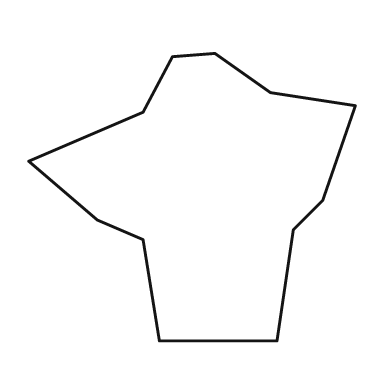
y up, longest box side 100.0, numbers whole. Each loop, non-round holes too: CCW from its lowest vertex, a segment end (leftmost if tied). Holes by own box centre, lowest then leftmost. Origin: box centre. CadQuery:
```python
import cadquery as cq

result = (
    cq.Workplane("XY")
    .moveTo(-10.0, -44.0)
    .lineTo(26.0, -44.0)
    .lineTo(31.0, -10.0)
    .lineTo(40.0, -1.0)
    .lineTo(50.0, 28.0)
    .lineTo(24.0, 32.0)
    .lineTo(7.0, 44.0)
    .lineTo(-6.0, 43.0)
    .lineTo(-15.0, 26.0)
    .lineTo(-50.0, 11.0)
    .lineTo(-29.0, -7.0)
    .lineTo(-15.0, -13.0)
    .close()
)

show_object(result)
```